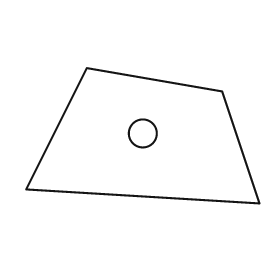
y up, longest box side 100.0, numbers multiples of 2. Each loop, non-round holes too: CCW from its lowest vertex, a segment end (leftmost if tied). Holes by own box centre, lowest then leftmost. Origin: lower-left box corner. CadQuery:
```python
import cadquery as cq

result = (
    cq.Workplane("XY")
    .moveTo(100.0, 0.0)
    .lineTo(84.0, 48.0)
    .lineTo(26.0, 58.0)
    .lineTo(0.0, 6.0)
    .close()
    .moveTo(50.0, 30.0)
    .circle(6.0)
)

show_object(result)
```